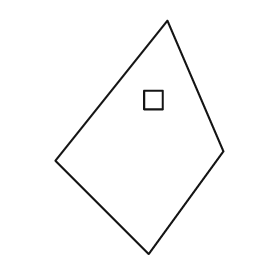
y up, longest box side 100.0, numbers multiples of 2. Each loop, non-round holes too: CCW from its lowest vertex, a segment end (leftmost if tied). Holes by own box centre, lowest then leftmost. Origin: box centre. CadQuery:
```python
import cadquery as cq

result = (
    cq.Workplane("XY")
    .moveTo(4.0, -50.0)
    .lineTo(36.0, -6.0)
    .lineTo(12.0, 50.0)
    .lineTo(-36.0, -10.0)
    .close()
    .moveTo(2.0, 12.0)
    .lineTo(10.0, 12.0)
    .lineTo(10.0, 20.0)
    .lineTo(2.0, 20.0)
    .close()
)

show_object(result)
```